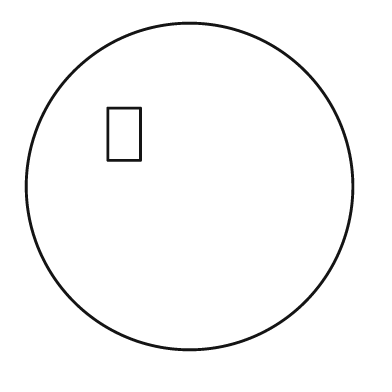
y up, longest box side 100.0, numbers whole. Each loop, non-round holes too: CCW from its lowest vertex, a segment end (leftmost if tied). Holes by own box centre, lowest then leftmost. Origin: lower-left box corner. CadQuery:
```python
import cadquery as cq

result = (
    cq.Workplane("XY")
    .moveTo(50.0, 50.0)
    .circle(50.0)
    .moveTo(25.0, 58.0)
    .lineTo(35.0, 58.0)
    .lineTo(35.0, 74.0)
    .lineTo(25.0, 74.0)
    .close()
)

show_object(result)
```